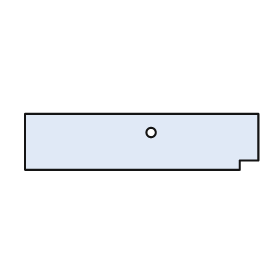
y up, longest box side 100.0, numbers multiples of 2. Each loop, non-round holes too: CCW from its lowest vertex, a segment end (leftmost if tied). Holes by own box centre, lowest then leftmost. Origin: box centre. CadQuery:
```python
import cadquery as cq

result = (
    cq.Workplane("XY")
    .moveTo(-50.0, -12.0)
    .lineTo(42.0, -12.0)
    .lineTo(42.0, -8.0)
    .lineTo(50.0, -8.0)
    .lineTo(50.0, 12.0)
    .lineTo(-50.0, 12.0)
    .close()
    .moveTo(4.0, 4.0)
    .circle(2.0)
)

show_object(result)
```